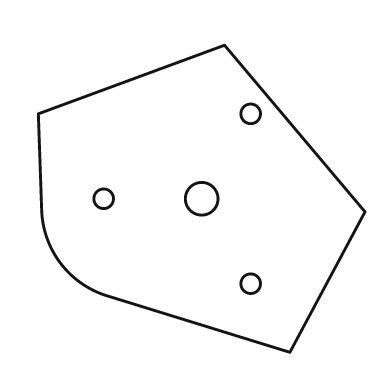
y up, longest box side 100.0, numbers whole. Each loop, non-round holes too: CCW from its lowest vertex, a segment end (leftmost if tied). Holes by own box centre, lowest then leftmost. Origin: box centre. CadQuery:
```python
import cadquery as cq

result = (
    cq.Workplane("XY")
    .moveTo(27.0, -47.0)
    .lineTo(50.0, -4.0)
    .lineTo(7.0, 47.0)
    .lineTo(-50.0, 26.0)
    .lineTo(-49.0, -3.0)
    .threePointArc((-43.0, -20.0), (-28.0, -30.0))
    .close()
    .moveTo(15.0, -26.0)
    .circle(3.0)
    .moveTo(-30.0, 0.0)
    .circle(3.0)
    .moveTo(0.0, 0.0)
    .circle(5.0)
    .moveTo(15.0, 26.0)
    .circle(3.0)
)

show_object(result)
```